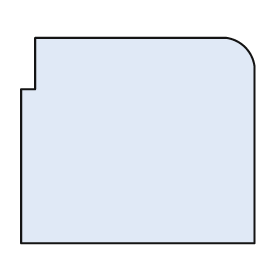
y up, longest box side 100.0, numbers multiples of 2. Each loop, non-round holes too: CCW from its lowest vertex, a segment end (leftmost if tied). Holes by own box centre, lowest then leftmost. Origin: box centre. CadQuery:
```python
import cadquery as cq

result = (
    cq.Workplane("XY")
    .moveTo(-50.0, -44.0)
    .lineTo(50.0, -44.0)
    .lineTo(50.0, 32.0)
    .threePointArc((46.0, 40.0), (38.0, 44.0))
    .lineTo(-44.0, 44.0)
    .lineTo(-44.0, 22.0)
    .lineTo(-50.0, 22.0)
    .close()
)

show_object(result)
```